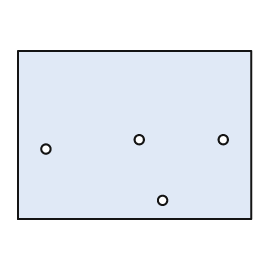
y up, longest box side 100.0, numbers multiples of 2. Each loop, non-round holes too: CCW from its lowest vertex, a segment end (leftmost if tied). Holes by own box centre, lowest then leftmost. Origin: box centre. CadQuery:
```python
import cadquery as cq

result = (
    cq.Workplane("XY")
    .moveTo(-50.0, -36.0)
    .lineTo(50.0, -36.0)
    .lineTo(50.0, 36.0)
    .lineTo(-50.0, 36.0)
    .close()
    .moveTo(12.0, -28.0)
    .circle(2.0)
    .moveTo(-38.0, -6.0)
    .circle(2.0)
    .moveTo(2.0, -2.0)
    .circle(2.0)
    .moveTo(38.0, -2.0)
    .circle(2.0)
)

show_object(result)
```